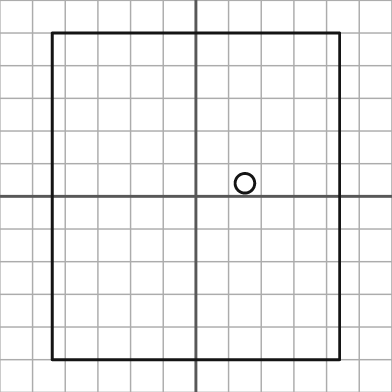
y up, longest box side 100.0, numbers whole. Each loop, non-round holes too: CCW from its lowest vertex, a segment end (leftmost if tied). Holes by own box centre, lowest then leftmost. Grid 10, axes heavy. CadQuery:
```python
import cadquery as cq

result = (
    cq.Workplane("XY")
    .moveTo(-44.0, -50.0)
    .lineTo(44.0, -50.0)
    .lineTo(44.0, 50.0)
    .lineTo(-44.0, 50.0)
    .close()
    .moveTo(15.0, 4.0)
    .circle(3.0)
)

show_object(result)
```